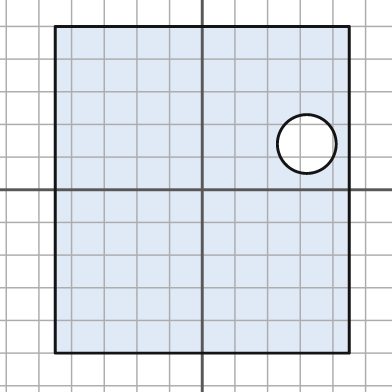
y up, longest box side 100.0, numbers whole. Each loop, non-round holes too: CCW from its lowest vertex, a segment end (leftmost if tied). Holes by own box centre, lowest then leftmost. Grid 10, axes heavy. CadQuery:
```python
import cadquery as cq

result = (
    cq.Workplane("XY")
    .moveTo(-45.0, -50.0)
    .lineTo(45.0, -50.0)
    .lineTo(45.0, 50.0)
    .lineTo(-45.0, 50.0)
    .close()
    .moveTo(32.0, 14.0)
    .circle(9.0)
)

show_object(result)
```